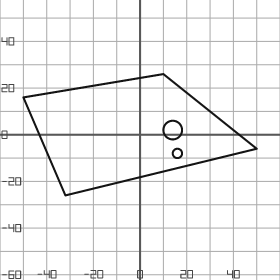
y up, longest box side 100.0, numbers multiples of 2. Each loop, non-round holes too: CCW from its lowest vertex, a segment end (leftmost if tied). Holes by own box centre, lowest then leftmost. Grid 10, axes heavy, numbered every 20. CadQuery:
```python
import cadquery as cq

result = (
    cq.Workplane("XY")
    .moveTo(-32.0, -26.0)
    .lineTo(50.0, -6.0)
    .lineTo(10.0, 26.0)
    .lineTo(-50.0, 16.0)
    .close()
    .moveTo(16.0, -8.0)
    .circle(2.0)
    .moveTo(14.0, 2.0)
    .circle(4.0)
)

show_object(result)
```